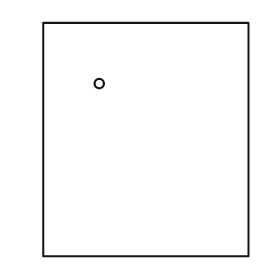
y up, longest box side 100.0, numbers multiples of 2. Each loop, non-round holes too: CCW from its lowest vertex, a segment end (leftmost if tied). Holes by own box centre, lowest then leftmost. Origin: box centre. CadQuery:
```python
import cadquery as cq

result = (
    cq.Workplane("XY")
    .moveTo(-44.0, -50.0)
    .lineTo(44.0, -50.0)
    .lineTo(44.0, 50.0)
    .lineTo(-44.0, 50.0)
    .close()
    .moveTo(-20.0, 24.0)
    .circle(2.0)
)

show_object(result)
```